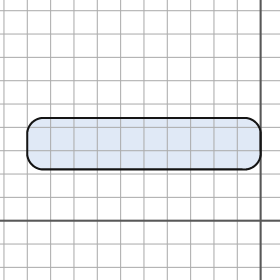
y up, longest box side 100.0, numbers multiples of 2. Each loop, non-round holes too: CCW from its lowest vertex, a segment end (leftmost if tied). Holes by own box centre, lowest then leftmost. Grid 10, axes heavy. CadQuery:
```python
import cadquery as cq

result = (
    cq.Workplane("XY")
    .moveTo(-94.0, 22.0)
    .lineTo(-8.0, 22.0)
    .threePointArc((-2.0, 24.0), (0.0, 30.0))
    .lineTo(0.0, 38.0)
    .threePointArc((-2.0, 42.0), (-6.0, 44.0))
    .lineTo(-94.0, 44.0)
    .threePointArc((-98.0, 42.0), (-100.0, 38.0))
    .lineTo(-100.0, 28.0)
    .threePointArc((-98.0, 24.0), (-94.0, 22.0))
    .close()
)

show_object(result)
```